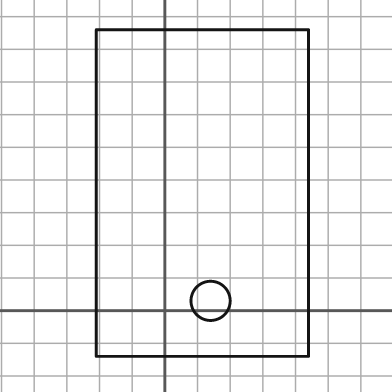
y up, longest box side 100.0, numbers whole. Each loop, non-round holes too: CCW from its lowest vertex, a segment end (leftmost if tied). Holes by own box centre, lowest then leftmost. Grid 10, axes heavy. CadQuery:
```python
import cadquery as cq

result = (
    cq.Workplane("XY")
    .moveTo(-21.0, -14.0)
    .lineTo(44.0, -14.0)
    .lineTo(44.0, 86.0)
    .lineTo(-21.0, 86.0)
    .close()
    .moveTo(14.0, 3.0)
    .circle(6.0)
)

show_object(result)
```